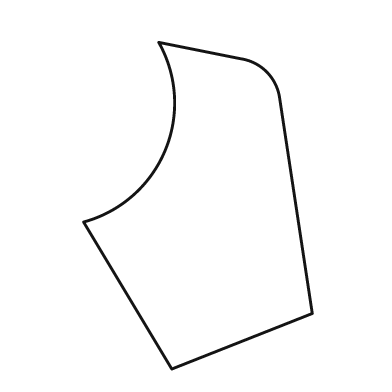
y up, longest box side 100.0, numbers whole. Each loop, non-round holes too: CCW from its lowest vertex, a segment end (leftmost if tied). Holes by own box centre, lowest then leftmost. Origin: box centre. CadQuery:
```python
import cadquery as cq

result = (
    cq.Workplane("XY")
    .moveTo(-8.0, -50.0)
    .lineTo(35.0, -33.0)
    .lineTo(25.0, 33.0)
    .threePointArc((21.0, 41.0), (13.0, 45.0))
    .lineTo(-12.0, 50.0)
    .threePointArc((-10.0, 17.0), (-35.0, -5.0))
    .close()
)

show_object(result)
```